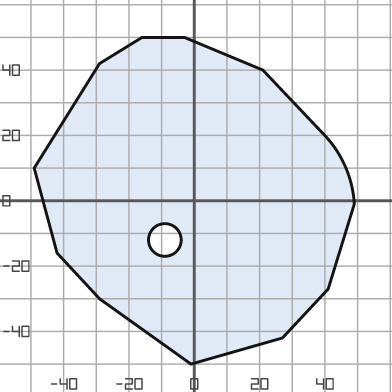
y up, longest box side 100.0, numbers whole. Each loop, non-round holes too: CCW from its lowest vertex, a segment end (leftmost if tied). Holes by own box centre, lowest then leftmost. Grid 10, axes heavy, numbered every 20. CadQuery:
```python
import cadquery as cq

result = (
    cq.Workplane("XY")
    .moveTo(-1.0, -50.0)
    .lineTo(27.0, -42.0)
    .lineTo(41.0, -27.0)
    .lineTo(49.0, -1.0)
    .threePointArc((46.0, 11.0), (39.0, 21.0))
    .lineTo(21.0, 40.0)
    .lineTo(-3.0, 50.0)
    .lineTo(-16.0, 50.0)
    .lineTo(-29.0, 42.0)
    .lineTo(-49.0, 10.0)
    .lineTo(-42.0, -16.0)
    .lineTo(-29.0, -30.0)
    .close()
    .moveTo(-9.0, -12.0)
    .circle(5.0)
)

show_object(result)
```